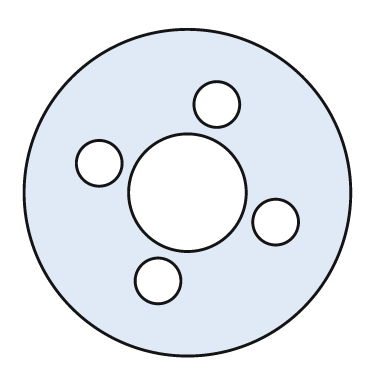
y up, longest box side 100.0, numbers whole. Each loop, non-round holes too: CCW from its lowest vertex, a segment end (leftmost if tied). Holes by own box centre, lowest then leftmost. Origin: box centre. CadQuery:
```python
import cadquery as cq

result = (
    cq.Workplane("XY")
    .moveTo(0.0, 0.0)
    .circle(50.0)
    .moveTo(-9.0, -27.0)
    .circle(7.0)
    .moveTo(27.0, -9.0)
    .circle(7.0)
    .moveTo(0.0, 0.0)
    .circle(18.0)
    .moveTo(-27.0, 9.0)
    .circle(7.0)
    .moveTo(9.0, 27.0)
    .circle(7.0)
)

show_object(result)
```